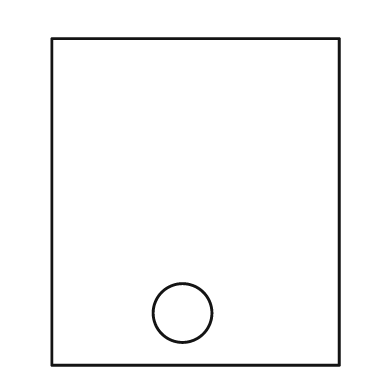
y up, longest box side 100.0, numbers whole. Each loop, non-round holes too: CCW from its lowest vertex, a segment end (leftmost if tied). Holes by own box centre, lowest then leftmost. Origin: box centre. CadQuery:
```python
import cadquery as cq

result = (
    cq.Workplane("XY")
    .moveTo(-44.0, -50.0)
    .lineTo(44.0, -50.0)
    .lineTo(44.0, 50.0)
    .lineTo(-44.0, 50.0)
    .close()
    .moveTo(-4.0, -34.0)
    .circle(9.0)
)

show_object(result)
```